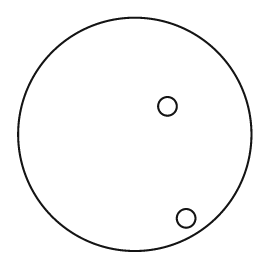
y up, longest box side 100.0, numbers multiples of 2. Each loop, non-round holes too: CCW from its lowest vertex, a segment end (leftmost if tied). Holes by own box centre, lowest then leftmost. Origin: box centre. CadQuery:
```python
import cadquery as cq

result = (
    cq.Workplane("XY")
    .moveTo(0.0, 0.0)
    .circle(50.0)
    .moveTo(22.0, -36.0)
    .circle(4.0)
    .moveTo(14.0, 12.0)
    .circle(4.0)
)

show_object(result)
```